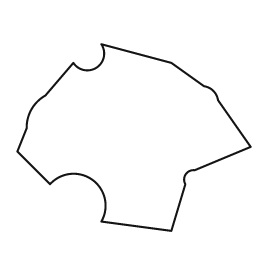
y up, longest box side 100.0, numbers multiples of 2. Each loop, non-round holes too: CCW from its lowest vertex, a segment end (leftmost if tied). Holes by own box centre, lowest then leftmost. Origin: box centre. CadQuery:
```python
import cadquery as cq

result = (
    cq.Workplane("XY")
    .moveTo(16.0, -40.0)
    .lineTo(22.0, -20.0)
    .threePointArc((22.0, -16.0), (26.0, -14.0))
    .lineTo(50.0, -4.0)
    .lineTo(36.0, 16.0)
    .threePointArc((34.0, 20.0), (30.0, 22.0))
    .lineTo(16.0, 32.0)
    .lineTo(-14.0, 40.0)
    .threePointArc((-16.0, 30.0), (-26.0, 32.0))
    .lineTo(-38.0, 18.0)
    .threePointArc((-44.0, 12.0), (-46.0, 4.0))
    .lineTo(-50.0, -6.0)
    .lineTo(-36.0, -20.0)
    .threePointArc((-18.0, -18.0), (-14.0, -36.0))
    .close()
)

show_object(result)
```